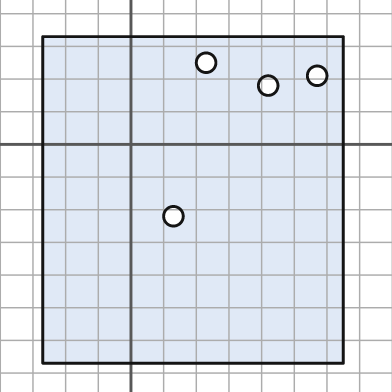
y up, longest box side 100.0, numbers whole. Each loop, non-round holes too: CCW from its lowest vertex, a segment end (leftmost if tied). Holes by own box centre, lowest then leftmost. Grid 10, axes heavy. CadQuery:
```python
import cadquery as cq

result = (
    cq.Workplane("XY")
    .moveTo(-27.0, -67.0)
    .lineTo(65.0, -67.0)
    .lineTo(65.0, 33.0)
    .lineTo(-27.0, 33.0)
    .close()
    .moveTo(13.0, -22.0)
    .circle(3.0)
    .moveTo(42.0, 18.0)
    .circle(3.0)
    .moveTo(57.0, 21.0)
    .circle(3.0)
    .moveTo(23.0, 25.0)
    .circle(3.0)
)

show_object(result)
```